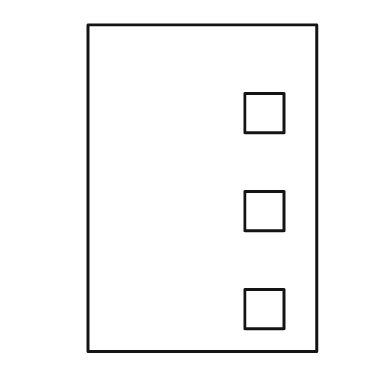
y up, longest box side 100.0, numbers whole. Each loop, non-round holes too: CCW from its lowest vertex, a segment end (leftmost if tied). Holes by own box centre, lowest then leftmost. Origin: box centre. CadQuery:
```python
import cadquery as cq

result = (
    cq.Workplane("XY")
    .moveTo(-35.0, -50.0)
    .lineTo(35.0, -50.0)
    .lineTo(35.0, 50.0)
    .lineTo(-35.0, 50.0)
    .close()
    .moveTo(13.0, -43.0)
    .lineTo(25.0, -43.0)
    .lineTo(25.0, -31.0)
    .lineTo(13.0, -31.0)
    .close()
    .moveTo(13.0, -13.0)
    .lineTo(25.0, -13.0)
    .lineTo(25.0, -1.0)
    .lineTo(13.0, -1.0)
    .close()
    .moveTo(13.0, 17.0)
    .lineTo(25.0, 17.0)
    .lineTo(25.0, 29.0)
    .lineTo(13.0, 29.0)
    .close()
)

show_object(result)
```